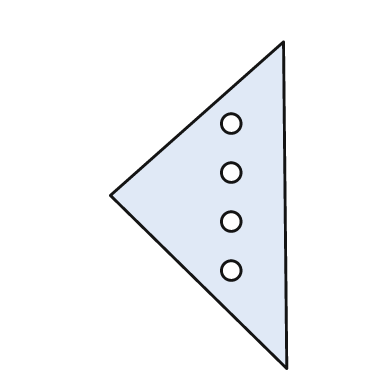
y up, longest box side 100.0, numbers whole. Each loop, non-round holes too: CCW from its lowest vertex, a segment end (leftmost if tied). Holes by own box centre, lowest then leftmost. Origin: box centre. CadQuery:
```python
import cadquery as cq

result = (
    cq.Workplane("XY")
    .moveTo(27.0, -50.0)
    .lineTo(26.0, 50.0)
    .lineTo(-27.0, 3.0)
    .close()
    .moveTo(10.0, -20.0)
    .circle(3.0)
    .moveTo(10.0, -5.0)
    .circle(3.0)
    .moveTo(10.0, 10.0)
    .circle(3.0)
    .moveTo(10.0, 25.0)
    .circle(3.0)
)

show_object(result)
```